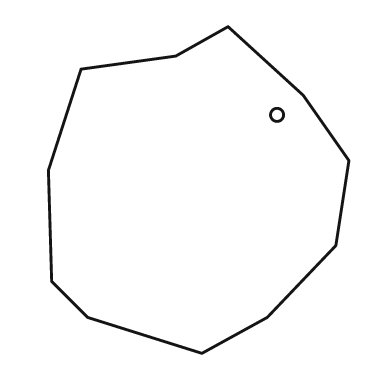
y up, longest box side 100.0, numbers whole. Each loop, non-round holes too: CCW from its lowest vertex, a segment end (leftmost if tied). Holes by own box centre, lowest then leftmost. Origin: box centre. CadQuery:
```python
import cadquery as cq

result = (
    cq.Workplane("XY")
    .moveTo(1.0, -50.0)
    .lineTo(21.0, -39.0)
    .lineTo(42.0, -17.0)
    .lineTo(46.0, 9.0)
    .lineTo(32.0, 29.0)
    .lineTo(9.0, 50.0)
    .lineTo(-7.0, 41.0)
    .lineTo(-36.0, 37.0)
    .lineTo(-46.0, 6.0)
    .lineTo(-45.0, -28.0)
    .lineTo(-34.0, -39.0)
    .close()
    .moveTo(24.0, 23.0)
    .circle(2.0)
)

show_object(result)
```